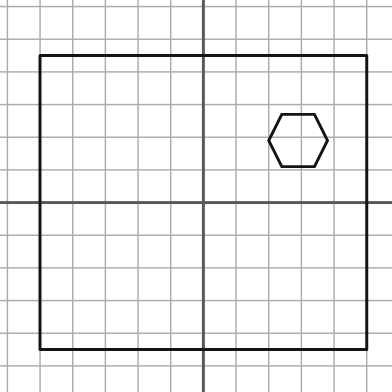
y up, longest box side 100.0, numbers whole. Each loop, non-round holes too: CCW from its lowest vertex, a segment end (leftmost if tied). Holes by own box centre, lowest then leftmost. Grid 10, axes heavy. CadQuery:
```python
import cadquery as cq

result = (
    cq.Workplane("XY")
    .moveTo(-50.0, -45.0)
    .lineTo(50.0, -45.0)
    .lineTo(50.0, 45.0)
    .lineTo(-50.0, 45.0)
    .close()
    .moveTo(24.0, 11.0)
    .lineTo(34.0, 11.0)
    .lineTo(38.0, 19.0)
    .lineTo(34.0, 27.0)
    .lineTo(24.0, 27.0)
    .lineTo(20.0, 19.0)
    .close()
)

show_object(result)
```